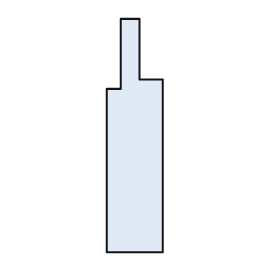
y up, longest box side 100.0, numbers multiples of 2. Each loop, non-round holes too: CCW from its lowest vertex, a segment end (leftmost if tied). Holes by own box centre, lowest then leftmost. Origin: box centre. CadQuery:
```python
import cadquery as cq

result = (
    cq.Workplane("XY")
    .moveTo(-12.0, -50.0)
    .lineTo(12.0, -50.0)
    .lineTo(12.0, 24.0)
    .lineTo(2.0, 24.0)
    .lineTo(2.0, 50.0)
    .lineTo(-6.0, 50.0)
    .lineTo(-6.0, 20.0)
    .lineTo(-12.0, 20.0)
    .close()
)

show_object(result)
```